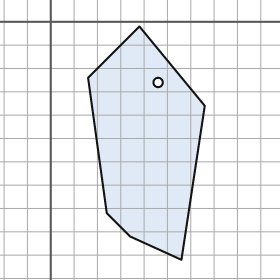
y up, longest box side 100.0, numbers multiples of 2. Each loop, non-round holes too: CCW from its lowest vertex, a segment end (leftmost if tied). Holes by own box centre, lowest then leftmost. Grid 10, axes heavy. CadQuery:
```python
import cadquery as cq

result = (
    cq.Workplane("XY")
    .moveTo(56.0, -102.0)
    .lineTo(66.0, -36.0)
    .lineTo(38.0, -2.0)
    .lineTo(16.0, -24.0)
    .lineTo(24.0, -82.0)
    .lineTo(34.0, -92.0)
    .close()
    .moveTo(46.0, -26.0)
    .circle(2.0)
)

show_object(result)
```